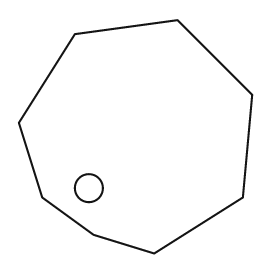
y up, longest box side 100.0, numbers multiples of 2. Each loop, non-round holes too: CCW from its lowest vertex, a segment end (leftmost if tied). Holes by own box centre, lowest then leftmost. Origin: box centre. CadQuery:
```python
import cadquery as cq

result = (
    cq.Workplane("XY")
    .moveTo(8.0, -50.0)
    .lineTo(46.0, -26.0)
    .lineTo(50.0, 18.0)
    .lineTo(18.0, 50.0)
    .lineTo(-26.0, 44.0)
    .lineTo(-50.0, 6.0)
    .lineTo(-40.0, -26.0)
    .lineTo(-18.0, -42.0)
    .close()
    .moveTo(-20.0, -22.0)
    .circle(6.0)
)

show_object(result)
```